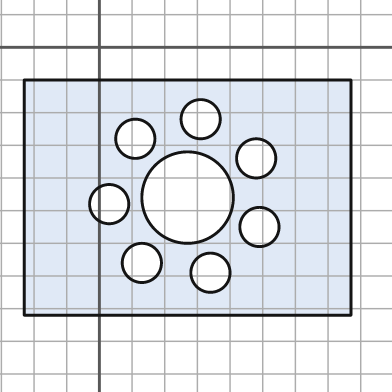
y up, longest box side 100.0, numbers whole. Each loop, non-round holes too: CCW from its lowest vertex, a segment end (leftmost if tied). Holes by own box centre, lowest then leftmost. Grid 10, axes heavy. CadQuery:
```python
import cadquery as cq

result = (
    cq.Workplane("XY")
    .moveTo(-23.0, -82.0)
    .lineTo(77.0, -82.0)
    .lineTo(77.0, -10.0)
    .lineTo(-23.0, -10.0)
    .close()
    .moveTo(34.0, -69.0)
    .circle(6.0)
    .moveTo(13.0, -66.0)
    .circle(6.0)
    .moveTo(49.0, -55.0)
    .circle(6.0)
    .moveTo(3.0, -48.0)
    .circle(6.0)
    .moveTo(27.0, -46.0)
    .circle(14.0)
    .moveTo(48.0, -34.0)
    .circle(6.0)
    .moveTo(11.0, -28.0)
    .circle(6.0)
    .moveTo(31.0, -22.0)
    .circle(6.0)
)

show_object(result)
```